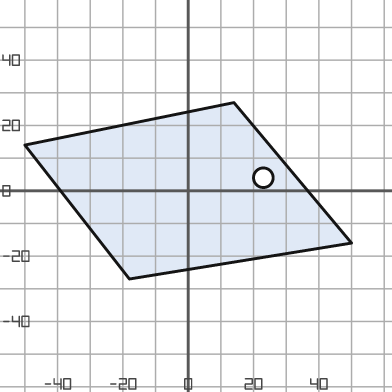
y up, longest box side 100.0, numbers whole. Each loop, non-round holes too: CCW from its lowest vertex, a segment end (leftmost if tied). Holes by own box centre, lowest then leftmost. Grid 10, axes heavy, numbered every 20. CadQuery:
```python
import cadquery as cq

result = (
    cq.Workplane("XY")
    .moveTo(-18.0, -27.0)
    .lineTo(50.0, -16.0)
    .lineTo(14.0, 27.0)
    .lineTo(-50.0, 14.0)
    .close()
    .moveTo(23.0, 4.0)
    .circle(3.0)
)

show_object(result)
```